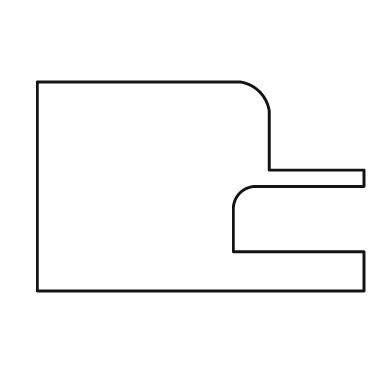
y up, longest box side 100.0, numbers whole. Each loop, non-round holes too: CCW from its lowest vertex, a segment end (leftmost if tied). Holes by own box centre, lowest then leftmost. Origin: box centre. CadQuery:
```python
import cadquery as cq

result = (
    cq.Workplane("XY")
    .moveTo(-50.0, -32.0)
    .lineTo(50.0, -32.0)
    .lineTo(50.0, -20.0)
    .lineTo(10.0, -20.0)
    .lineTo(10.0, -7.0)
    .threePointArc((12.0, -2.0), (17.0, 0.0))
    .lineTo(50.0, 0.0)
    .lineTo(50.0, 5.0)
    .lineTo(21.0, 5.0)
    .lineTo(21.0, 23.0)
    .threePointArc((18.0, 29.0), (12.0, 32.0))
    .lineTo(-50.0, 32.0)
    .close()
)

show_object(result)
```